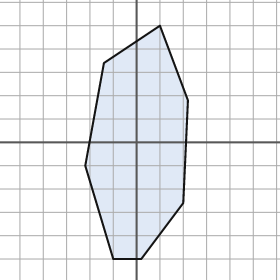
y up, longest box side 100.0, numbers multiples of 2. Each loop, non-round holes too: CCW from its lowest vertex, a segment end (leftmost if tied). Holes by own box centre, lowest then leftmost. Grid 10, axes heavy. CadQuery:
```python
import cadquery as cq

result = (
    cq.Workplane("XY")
    .moveTo(-10.0, -50.0)
    .lineTo(2.0, -50.0)
    .lineTo(20.0, -26.0)
    .lineTo(22.0, 18.0)
    .lineTo(10.0, 50.0)
    .lineTo(-14.0, 34.0)
    .lineTo(-22.0, -10.0)
    .close()
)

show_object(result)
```